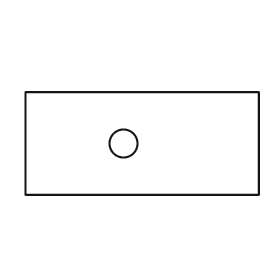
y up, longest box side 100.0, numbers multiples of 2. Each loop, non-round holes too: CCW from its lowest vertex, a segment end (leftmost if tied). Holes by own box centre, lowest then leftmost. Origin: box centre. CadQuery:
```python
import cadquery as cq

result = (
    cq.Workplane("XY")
    .moveTo(-50.0, -22.0)
    .lineTo(50.0, -22.0)
    .lineTo(50.0, 22.0)
    .lineTo(-50.0, 22.0)
    .close()
    .moveTo(-8.0, 0.0)
    .circle(6.0)
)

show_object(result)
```